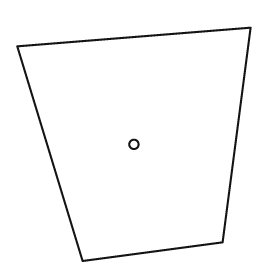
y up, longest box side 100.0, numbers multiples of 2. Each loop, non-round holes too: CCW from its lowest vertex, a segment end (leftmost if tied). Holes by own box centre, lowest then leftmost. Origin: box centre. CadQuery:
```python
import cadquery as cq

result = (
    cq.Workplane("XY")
    .moveTo(-22.0, -50.0)
    .lineTo(38.0, -42.0)
    .lineTo(50.0, 50.0)
    .lineTo(-50.0, 42.0)
    .close()
    .moveTo(0.0, 0.0)
    .circle(2.0)
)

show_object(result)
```